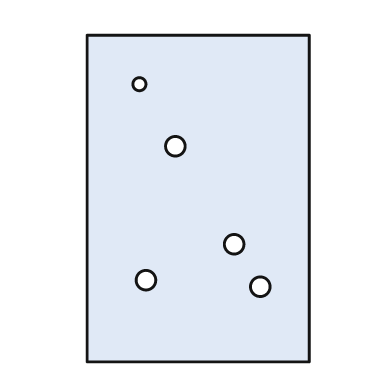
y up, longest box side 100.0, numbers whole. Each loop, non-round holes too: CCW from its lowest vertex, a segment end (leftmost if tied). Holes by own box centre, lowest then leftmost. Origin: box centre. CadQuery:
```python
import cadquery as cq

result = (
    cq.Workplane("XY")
    .moveTo(-34.0, -50.0)
    .lineTo(34.0, -50.0)
    .lineTo(34.0, 50.0)
    .lineTo(-34.0, 50.0)
    .close()
    .moveTo(19.0, -27.0)
    .circle(3.0)
    .moveTo(-16.0, -25.0)
    .circle(3.0)
    .moveTo(11.0, -14.0)
    .circle(3.0)
    .moveTo(-7.0, 16.0)
    .circle(3.0)
    .moveTo(-18.0, 35.0)
    .circle(2.0)
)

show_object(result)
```